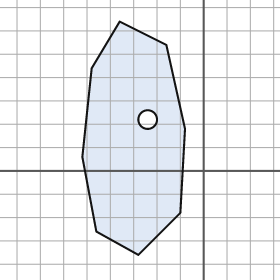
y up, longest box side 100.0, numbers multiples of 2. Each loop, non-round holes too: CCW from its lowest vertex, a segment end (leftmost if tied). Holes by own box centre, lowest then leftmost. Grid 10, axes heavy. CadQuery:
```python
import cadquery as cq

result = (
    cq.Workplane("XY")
    .moveTo(-28.0, -36.0)
    .lineTo(-10.0, -18.0)
    .lineTo(-8.0, 18.0)
    .lineTo(-16.0, 54.0)
    .lineTo(-36.0, 64.0)
    .lineTo(-48.0, 44.0)
    .lineTo(-52.0, 6.0)
    .lineTo(-46.0, -26.0)
    .close()
    .moveTo(-24.0, 22.0)
    .circle(4.0)
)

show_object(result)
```